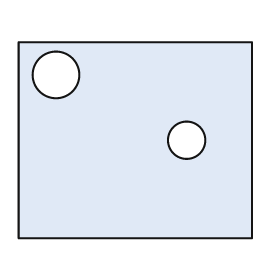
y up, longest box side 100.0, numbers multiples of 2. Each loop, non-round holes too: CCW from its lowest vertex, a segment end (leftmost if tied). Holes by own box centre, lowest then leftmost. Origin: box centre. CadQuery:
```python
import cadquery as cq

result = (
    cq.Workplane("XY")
    .moveTo(-50.0, -42.0)
    .lineTo(50.0, -42.0)
    .lineTo(50.0, 42.0)
    .lineTo(-50.0, 42.0)
    .close()
    .moveTo(22.0, 0.0)
    .circle(8.0)
    .moveTo(-34.0, 28.0)
    .circle(10.0)
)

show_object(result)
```